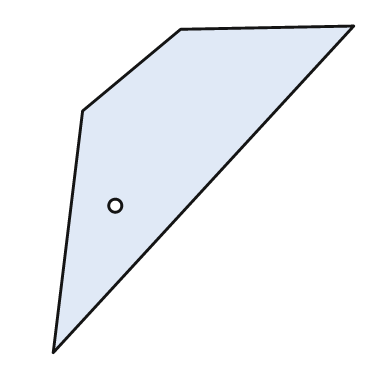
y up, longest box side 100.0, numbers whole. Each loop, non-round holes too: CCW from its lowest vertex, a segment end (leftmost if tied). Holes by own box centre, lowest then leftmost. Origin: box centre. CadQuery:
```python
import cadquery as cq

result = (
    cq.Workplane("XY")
    .moveTo(-46.0, -50.0)
    .lineTo(46.0, 50.0)
    .lineTo(-7.0, 49.0)
    .lineTo(-37.0, 24.0)
    .close()
    .moveTo(-27.0, -5.0)
    .circle(2.0)
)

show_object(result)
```